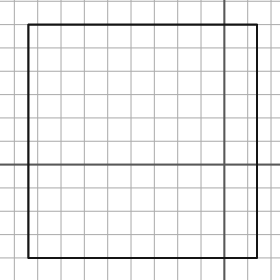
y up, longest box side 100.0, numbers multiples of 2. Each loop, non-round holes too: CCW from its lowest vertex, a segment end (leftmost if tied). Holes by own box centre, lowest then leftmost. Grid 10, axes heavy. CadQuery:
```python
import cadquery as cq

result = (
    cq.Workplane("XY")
    .moveTo(-84.0, -40.0)
    .lineTo(14.0, -40.0)
    .lineTo(14.0, 60.0)
    .lineTo(-84.0, 60.0)
    .close()
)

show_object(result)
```